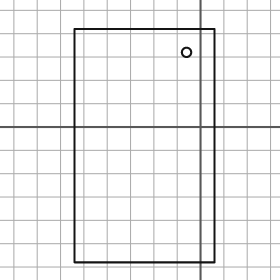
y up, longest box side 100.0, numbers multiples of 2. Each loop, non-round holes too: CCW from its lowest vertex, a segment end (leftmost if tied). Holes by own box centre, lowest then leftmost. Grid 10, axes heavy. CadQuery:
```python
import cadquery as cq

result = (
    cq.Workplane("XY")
    .moveTo(-54.0, -58.0)
    .lineTo(6.0, -58.0)
    .lineTo(6.0, 42.0)
    .lineTo(-54.0, 42.0)
    .close()
    .moveTo(-6.0, 32.0)
    .circle(2.0)
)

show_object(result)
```